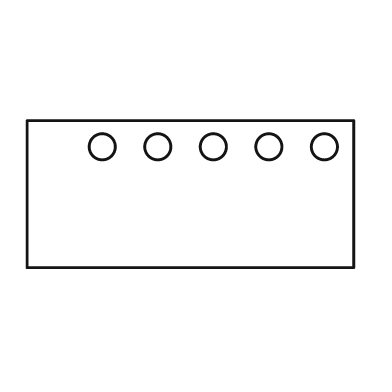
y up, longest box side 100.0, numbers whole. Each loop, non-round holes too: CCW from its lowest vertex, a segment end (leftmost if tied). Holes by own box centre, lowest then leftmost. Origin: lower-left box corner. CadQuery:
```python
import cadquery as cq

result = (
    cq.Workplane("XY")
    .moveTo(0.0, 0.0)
    .lineTo(100.0, 0.0)
    .lineTo(100.0, 45.0)
    .lineTo(0.0, 45.0)
    .close()
    .moveTo(23.0, 37.0)
    .circle(4.0)
    .moveTo(40.0, 37.0)
    .circle(4.0)
    .moveTo(57.0, 37.0)
    .circle(4.0)
    .moveTo(74.0, 37.0)
    .circle(4.0)
    .moveTo(91.0, 37.0)
    .circle(4.0)
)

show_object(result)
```